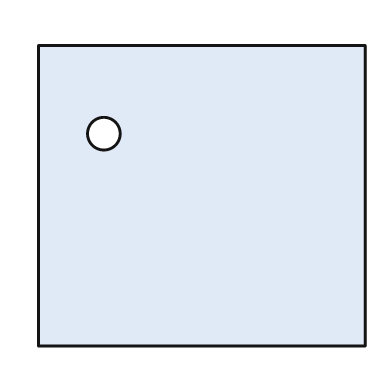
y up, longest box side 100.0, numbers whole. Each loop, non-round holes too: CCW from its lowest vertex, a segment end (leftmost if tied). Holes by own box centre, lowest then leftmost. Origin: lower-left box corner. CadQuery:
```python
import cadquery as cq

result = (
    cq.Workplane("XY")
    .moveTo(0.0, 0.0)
    .lineTo(100.0, 0.0)
    .lineTo(100.0, 92.0)
    .lineTo(0.0, 92.0)
    .close()
    .moveTo(20.0, 65.0)
    .circle(5.0)
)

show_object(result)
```